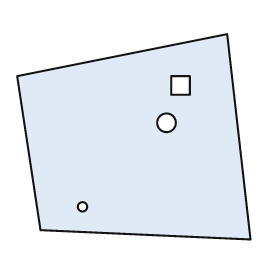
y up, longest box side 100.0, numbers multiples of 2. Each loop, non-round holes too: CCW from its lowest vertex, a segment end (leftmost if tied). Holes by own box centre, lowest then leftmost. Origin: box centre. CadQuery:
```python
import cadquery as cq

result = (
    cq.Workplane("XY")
    .moveTo(50.0, -44.0)
    .lineTo(40.0, 44.0)
    .lineTo(-50.0, 26.0)
    .lineTo(-40.0, -40.0)
    .close()
    .moveTo(-22.0, -30.0)
    .circle(2.0)
    .moveTo(14.0, 6.0)
    .circle(4.0)
    .moveTo(16.0, 18.0)
    .lineTo(24.0, 18.0)
    .lineTo(24.0, 26.0)
    .lineTo(16.0, 26.0)
    .close()
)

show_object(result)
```